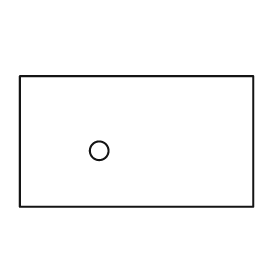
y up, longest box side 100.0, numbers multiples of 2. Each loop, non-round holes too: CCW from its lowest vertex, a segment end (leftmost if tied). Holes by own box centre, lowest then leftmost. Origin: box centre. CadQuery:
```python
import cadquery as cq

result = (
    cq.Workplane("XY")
    .moveTo(-50.0, -28.0)
    .lineTo(50.0, -28.0)
    .lineTo(50.0, 28.0)
    .lineTo(-50.0, 28.0)
    .close()
    .moveTo(-16.0, -4.0)
    .circle(4.0)
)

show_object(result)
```